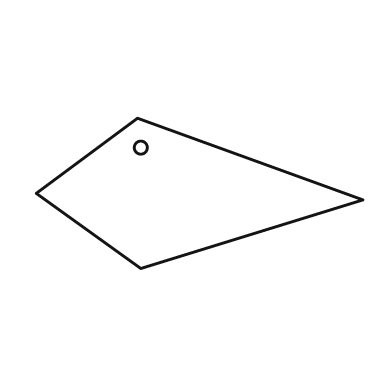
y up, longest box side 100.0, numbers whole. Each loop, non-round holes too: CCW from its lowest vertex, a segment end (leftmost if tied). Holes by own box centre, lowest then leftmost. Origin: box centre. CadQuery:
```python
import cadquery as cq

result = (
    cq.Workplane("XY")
    .moveTo(-18.0, -23.0)
    .lineTo(50.0, -2.0)
    .lineTo(-19.0, 23.0)
    .lineTo(-50.0, 0.0)
    .close()
    .moveTo(-18.0, 14.0)
    .circle(2.0)
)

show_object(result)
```